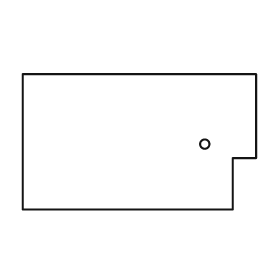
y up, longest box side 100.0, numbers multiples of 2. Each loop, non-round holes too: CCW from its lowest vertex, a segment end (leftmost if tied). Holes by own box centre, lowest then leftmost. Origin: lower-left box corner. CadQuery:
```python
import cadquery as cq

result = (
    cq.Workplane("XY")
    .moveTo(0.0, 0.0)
    .lineTo(90.0, 0.0)
    .lineTo(90.0, 22.0)
    .lineTo(100.0, 22.0)
    .lineTo(100.0, 58.0)
    .lineTo(0.0, 58.0)
    .close()
    .moveTo(78.0, 28.0)
    .circle(2.0)
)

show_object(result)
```